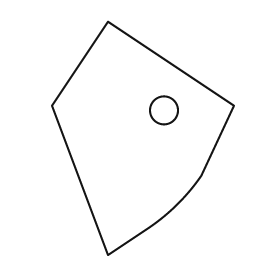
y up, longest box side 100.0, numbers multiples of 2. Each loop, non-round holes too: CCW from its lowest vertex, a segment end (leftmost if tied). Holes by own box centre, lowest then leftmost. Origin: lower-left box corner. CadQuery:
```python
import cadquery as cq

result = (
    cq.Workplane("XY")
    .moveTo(24.0, 0.0)
    .lineTo(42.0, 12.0)
    .threePointArc((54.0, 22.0), (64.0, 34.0))
    .lineTo(78.0, 64.0)
    .lineTo(24.0, 100.0)
    .lineTo(0.0, 64.0)
    .close()
    .moveTo(48.0, 62.0)
    .circle(6.0)
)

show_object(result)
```